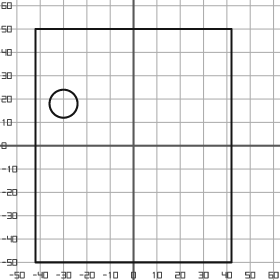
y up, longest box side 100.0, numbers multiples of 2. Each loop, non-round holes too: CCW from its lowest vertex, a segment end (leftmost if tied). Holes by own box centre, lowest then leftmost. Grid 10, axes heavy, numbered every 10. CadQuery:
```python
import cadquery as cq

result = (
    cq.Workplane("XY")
    .moveTo(-42.0, -50.0)
    .lineTo(42.0, -50.0)
    .lineTo(42.0, 50.0)
    .lineTo(-42.0, 50.0)
    .close()
    .moveTo(-30.0, 18.0)
    .circle(6.0)
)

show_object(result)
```